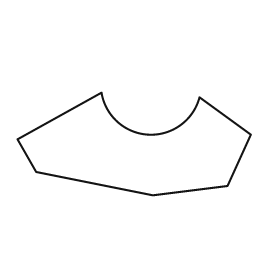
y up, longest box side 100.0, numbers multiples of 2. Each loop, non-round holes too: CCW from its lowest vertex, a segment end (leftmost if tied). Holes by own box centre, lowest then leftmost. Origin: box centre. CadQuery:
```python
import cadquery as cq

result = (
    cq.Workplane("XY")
    .moveTo(8.0, -22.0)
    .lineTo(40.0, -18.0)
    .lineTo(50.0, 4.0)
    .lineTo(28.0, 20.0)
    .threePointArc((6.0, 4.0), (-14.0, 22.0))
    .lineTo(-50.0, 2.0)
    .lineTo(-42.0, -12.0)
    .close()
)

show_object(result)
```